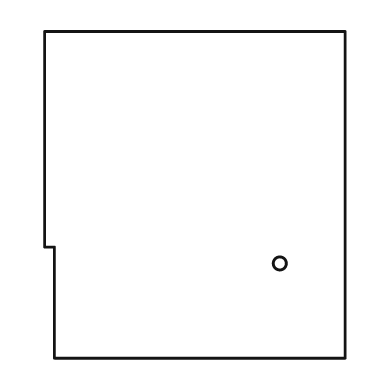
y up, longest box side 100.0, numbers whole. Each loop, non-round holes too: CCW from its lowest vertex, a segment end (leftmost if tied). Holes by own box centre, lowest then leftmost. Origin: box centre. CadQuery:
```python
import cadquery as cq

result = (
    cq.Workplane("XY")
    .moveTo(-43.0, -50.0)
    .lineTo(46.0, -50.0)
    .lineTo(46.0, 50.0)
    .lineTo(-46.0, 50.0)
    .lineTo(-46.0, -16.0)
    .lineTo(-43.0, -16.0)
    .close()
    .moveTo(26.0, -21.0)
    .circle(2.0)
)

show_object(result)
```